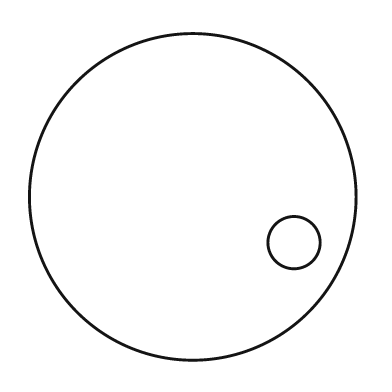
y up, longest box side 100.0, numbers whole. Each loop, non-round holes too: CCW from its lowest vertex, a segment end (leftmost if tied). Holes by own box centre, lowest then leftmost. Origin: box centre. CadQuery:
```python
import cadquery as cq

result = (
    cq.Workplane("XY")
    .moveTo(0.0, 0.0)
    .circle(50.0)
    .moveTo(31.0, -14.0)
    .circle(8.0)
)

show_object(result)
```